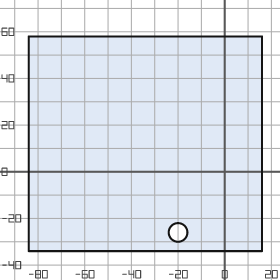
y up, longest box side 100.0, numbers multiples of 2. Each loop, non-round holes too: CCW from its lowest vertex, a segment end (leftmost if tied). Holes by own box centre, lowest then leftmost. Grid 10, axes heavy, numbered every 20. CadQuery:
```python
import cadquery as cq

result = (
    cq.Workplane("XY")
    .moveTo(-84.0, -34.0)
    .lineTo(16.0, -34.0)
    .lineTo(16.0, 58.0)
    .lineTo(-84.0, 58.0)
    .close()
    .moveTo(-20.0, -26.0)
    .circle(4.0)
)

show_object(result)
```